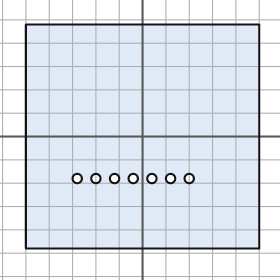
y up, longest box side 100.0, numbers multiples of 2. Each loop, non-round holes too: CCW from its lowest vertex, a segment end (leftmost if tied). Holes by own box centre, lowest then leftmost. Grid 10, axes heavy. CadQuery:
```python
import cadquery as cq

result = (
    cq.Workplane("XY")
    .moveTo(-50.0, -48.0)
    .lineTo(50.0, -48.0)
    .lineTo(50.0, 48.0)
    .lineTo(-50.0, 48.0)
    .close()
    .moveTo(-28.0, -18.0)
    .circle(2.0)
    .moveTo(-20.0, -18.0)
    .circle(2.0)
    .moveTo(-12.0, -18.0)
    .circle(2.0)
    .moveTo(-4.0, -18.0)
    .circle(2.0)
    .moveTo(4.0, -18.0)
    .circle(2.0)
    .moveTo(12.0, -18.0)
    .circle(2.0)
    .moveTo(20.0, -18.0)
    .circle(2.0)
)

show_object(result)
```